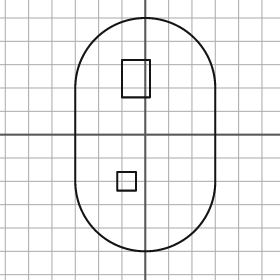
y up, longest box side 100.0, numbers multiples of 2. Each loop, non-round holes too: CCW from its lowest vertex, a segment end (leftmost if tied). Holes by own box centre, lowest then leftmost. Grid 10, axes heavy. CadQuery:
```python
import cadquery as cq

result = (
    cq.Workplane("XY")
    .moveTo(-30.0, -20.0)
    .threePointArc((0.0, -50.0), (30.0, -20.0))
    .lineTo(30.0, 20.0)
    .threePointArc((0.0, 50.0), (-30.0, 20.0))
    .close()
    .moveTo(-12.0, -24.0)
    .lineTo(-4.0, -24.0)
    .lineTo(-4.0, -16.0)
    .lineTo(-12.0, -16.0)
    .close()
    .moveTo(-10.0, 16.0)
    .lineTo(2.0, 16.0)
    .lineTo(2.0, 32.0)
    .lineTo(-10.0, 32.0)
    .close()
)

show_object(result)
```